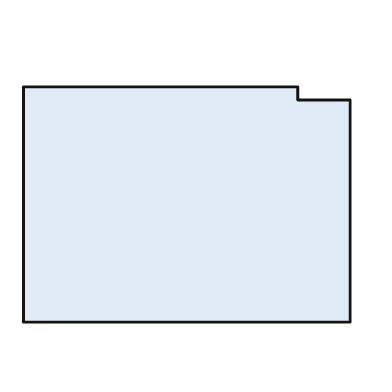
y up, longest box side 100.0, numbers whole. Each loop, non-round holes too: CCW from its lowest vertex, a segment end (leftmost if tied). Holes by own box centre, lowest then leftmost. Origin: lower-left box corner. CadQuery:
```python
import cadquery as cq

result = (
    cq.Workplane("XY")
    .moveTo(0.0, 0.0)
    .lineTo(100.0, 0.0)
    .lineTo(100.0, 68.0)
    .lineTo(84.0, 68.0)
    .lineTo(84.0, 72.0)
    .lineTo(0.0, 72.0)
    .close()
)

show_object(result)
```